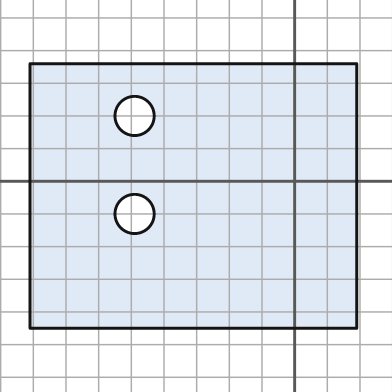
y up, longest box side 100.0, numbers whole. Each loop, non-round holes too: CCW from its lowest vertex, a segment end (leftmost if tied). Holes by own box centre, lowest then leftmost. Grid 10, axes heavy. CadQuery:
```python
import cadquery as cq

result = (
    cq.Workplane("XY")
    .moveTo(-81.0, -45.0)
    .lineTo(19.0, -45.0)
    .lineTo(19.0, 36.0)
    .lineTo(-81.0, 36.0)
    .close()
    .moveTo(-49.0, -10.0)
    .circle(6.0)
    .moveTo(-49.0, 20.0)
    .circle(6.0)
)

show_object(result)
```